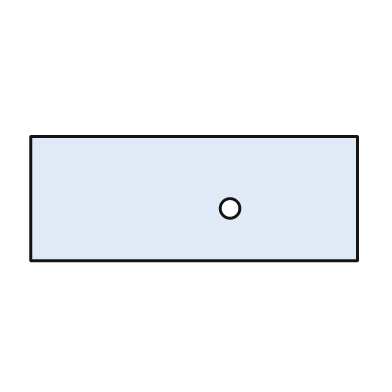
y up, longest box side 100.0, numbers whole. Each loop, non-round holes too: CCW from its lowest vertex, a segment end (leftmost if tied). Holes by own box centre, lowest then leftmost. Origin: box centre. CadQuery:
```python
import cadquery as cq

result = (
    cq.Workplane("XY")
    .moveTo(-50.0, -19.0)
    .lineTo(50.0, -19.0)
    .lineTo(50.0, 19.0)
    .lineTo(-50.0, 19.0)
    .close()
    .moveTo(11.0, -3.0)
    .circle(3.0)
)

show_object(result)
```